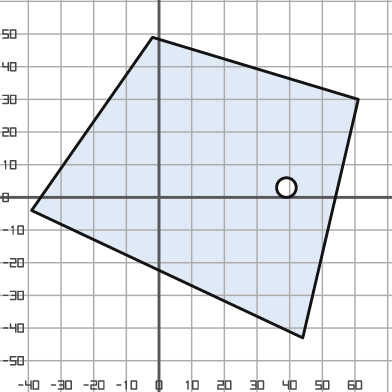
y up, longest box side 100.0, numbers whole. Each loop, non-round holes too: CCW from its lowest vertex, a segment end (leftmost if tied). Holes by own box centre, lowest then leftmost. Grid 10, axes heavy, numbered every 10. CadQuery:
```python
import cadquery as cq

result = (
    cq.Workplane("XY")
    .moveTo(44.0, -43.0)
    .lineTo(61.0, 30.0)
    .lineTo(-2.0, 49.0)
    .lineTo(-39.0, -4.0)
    .close()
    .moveTo(39.0, 3.0)
    .circle(3.0)
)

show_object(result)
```